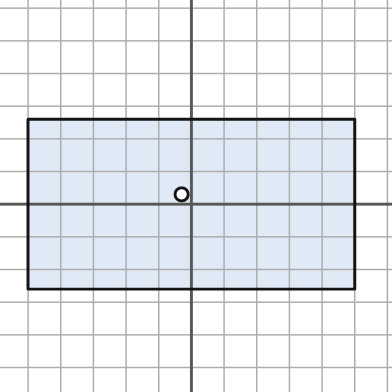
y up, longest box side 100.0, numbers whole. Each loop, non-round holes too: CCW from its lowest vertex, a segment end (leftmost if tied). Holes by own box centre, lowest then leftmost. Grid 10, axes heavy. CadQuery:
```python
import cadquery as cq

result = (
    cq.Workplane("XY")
    .moveTo(-50.0, -26.0)
    .lineTo(50.0, -26.0)
    .lineTo(50.0, 26.0)
    .lineTo(-50.0, 26.0)
    .close()
    .moveTo(-3.0, 3.0)
    .circle(2.0)
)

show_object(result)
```